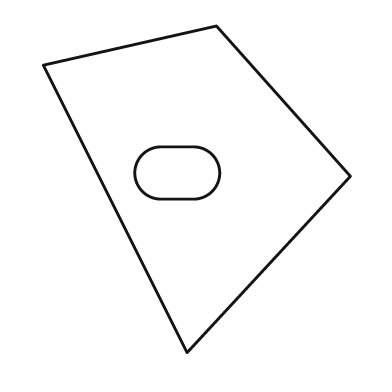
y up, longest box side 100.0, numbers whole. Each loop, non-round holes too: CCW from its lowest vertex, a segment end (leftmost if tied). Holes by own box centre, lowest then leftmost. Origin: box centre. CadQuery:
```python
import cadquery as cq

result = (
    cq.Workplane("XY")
    .moveTo(-3.0, -50.0)
    .lineTo(47.0, 4.0)
    .lineTo(6.0, 50.0)
    .lineTo(-47.0, 38.0)
    .close()
    .moveTo(-11.0, -3.0)
    .lineTo(-1.0, -3.0)
    .threePointArc((7.0, 5.0), (-1.0, 13.0))
    .lineTo(-11.0, 13.0)
    .threePointArc((-19.0, 5.0), (-11.0, -3.0))
    .close()
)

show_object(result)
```